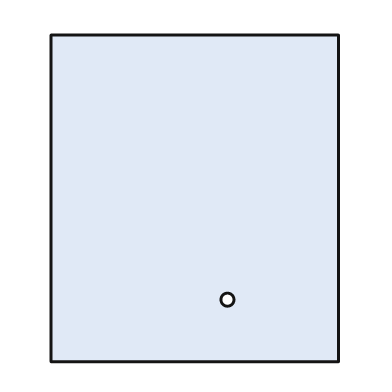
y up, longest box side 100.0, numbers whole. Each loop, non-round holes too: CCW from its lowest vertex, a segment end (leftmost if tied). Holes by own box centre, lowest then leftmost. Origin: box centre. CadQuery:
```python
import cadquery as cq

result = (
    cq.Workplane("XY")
    .moveTo(-44.0, -50.0)
    .lineTo(44.0, -50.0)
    .lineTo(44.0, 50.0)
    .lineTo(-44.0, 50.0)
    .close()
    .moveTo(10.0, -31.0)
    .circle(2.0)
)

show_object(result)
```